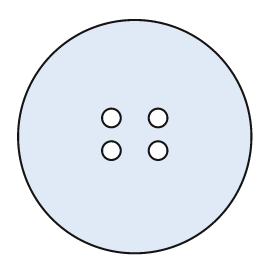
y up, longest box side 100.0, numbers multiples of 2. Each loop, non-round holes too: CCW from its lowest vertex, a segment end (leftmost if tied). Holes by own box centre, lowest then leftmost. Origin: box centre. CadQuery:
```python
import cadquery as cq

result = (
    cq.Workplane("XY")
    .moveTo(0.0, 0.0)
    .circle(50.0)
    .moveTo(-10.0, -6.0)
    .circle(4.0)
    .moveTo(10.0, -6.0)
    .circle(4.0)
    .moveTo(-10.0, 8.0)
    .circle(4.0)
    .moveTo(10.0, 8.0)
    .circle(4.0)
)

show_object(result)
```